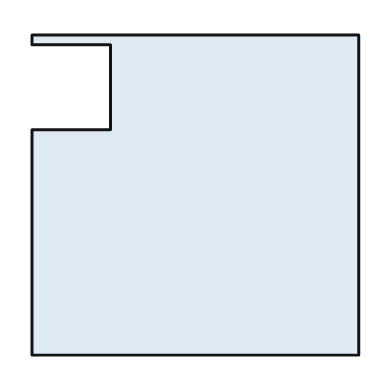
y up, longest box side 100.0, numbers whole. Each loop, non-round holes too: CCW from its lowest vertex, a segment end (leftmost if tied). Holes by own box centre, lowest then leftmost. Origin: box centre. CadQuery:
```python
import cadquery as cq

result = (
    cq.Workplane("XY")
    .moveTo(-50.0, -49.0)
    .lineTo(50.0, -49.0)
    .lineTo(50.0, 49.0)
    .lineTo(-50.0, 49.0)
    .lineTo(-50.0, 46.0)
    .lineTo(-26.0, 46.0)
    .lineTo(-26.0, 20.0)
    .lineTo(-50.0, 20.0)
    .close()
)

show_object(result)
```